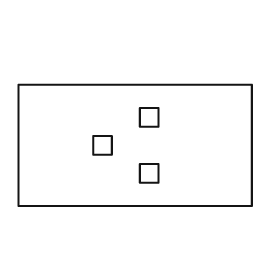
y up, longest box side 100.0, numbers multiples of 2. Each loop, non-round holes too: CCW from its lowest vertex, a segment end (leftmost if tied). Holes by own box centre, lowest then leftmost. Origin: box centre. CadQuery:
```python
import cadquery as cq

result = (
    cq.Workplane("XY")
    .moveTo(-50.0, -26.0)
    .lineTo(50.0, -26.0)
    .lineTo(50.0, 26.0)
    .lineTo(-50.0, 26.0)
    .close()
    .moveTo(2.0, -16.0)
    .lineTo(10.0, -16.0)
    .lineTo(10.0, -8.0)
    .lineTo(2.0, -8.0)
    .close()
    .moveTo(-18.0, -4.0)
    .lineTo(-10.0, -4.0)
    .lineTo(-10.0, 4.0)
    .lineTo(-18.0, 4.0)
    .close()
    .moveTo(2.0, 8.0)
    .lineTo(10.0, 8.0)
    .lineTo(10.0, 16.0)
    .lineTo(2.0, 16.0)
    .close()
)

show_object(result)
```